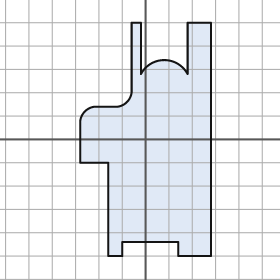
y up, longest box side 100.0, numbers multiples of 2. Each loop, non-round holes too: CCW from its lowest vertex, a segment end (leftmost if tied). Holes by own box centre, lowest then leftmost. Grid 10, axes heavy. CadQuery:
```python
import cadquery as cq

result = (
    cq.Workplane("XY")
    .moveTo(-16.0, -50.0)
    .lineTo(-10.0, -50.0)
    .lineTo(-10.0, -44.0)
    .lineTo(14.0, -44.0)
    .lineTo(14.0, -50.0)
    .lineTo(28.0, -50.0)
    .lineTo(28.0, 50.0)
    .lineTo(18.0, 50.0)
    .lineTo(18.0, 28.0)
    .threePointArc((8.0, 34.0), (-2.0, 28.0))
    .lineTo(-2.0, 50.0)
    .lineTo(-6.0, 50.0)
    .lineTo(-6.0, 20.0)
    .threePointArc((-8.0, 16.0), (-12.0, 14.0))
    .lineTo(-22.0, 14.0)
    .threePointArc((-26.0, 12.0), (-28.0, 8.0))
    .lineTo(-28.0, -10.0)
    .lineTo(-16.0, -10.0)
    .close()
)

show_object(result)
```